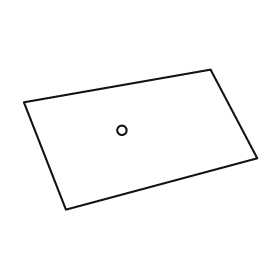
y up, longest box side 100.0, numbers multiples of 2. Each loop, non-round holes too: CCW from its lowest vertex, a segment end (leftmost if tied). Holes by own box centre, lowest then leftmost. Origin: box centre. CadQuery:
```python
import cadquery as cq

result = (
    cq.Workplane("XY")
    .moveTo(-32.0, -30.0)
    .lineTo(50.0, -8.0)
    .lineTo(30.0, 30.0)
    .lineTo(-50.0, 16.0)
    .close()
    .moveTo(-8.0, 4.0)
    .circle(2.0)
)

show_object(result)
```